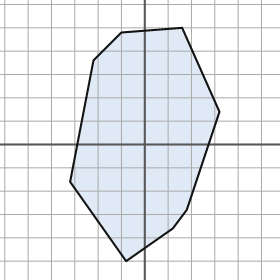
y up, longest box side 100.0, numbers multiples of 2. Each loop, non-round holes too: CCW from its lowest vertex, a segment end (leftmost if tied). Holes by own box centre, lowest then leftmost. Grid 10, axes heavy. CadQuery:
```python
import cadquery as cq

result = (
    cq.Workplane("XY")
    .moveTo(-8.0, -50.0)
    .lineTo(12.0, -36.0)
    .lineTo(18.0, -28.0)
    .lineTo(32.0, 14.0)
    .lineTo(16.0, 50.0)
    .lineTo(-10.0, 48.0)
    .lineTo(-22.0, 36.0)
    .lineTo(-32.0, -16.0)
    .close()
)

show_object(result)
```